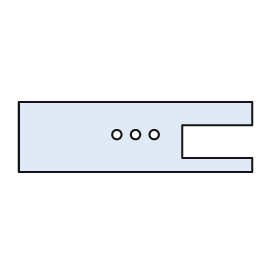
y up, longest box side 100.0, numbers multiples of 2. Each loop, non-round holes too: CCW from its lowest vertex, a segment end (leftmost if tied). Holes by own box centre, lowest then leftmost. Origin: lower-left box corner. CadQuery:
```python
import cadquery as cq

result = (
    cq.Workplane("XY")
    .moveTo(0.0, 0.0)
    .lineTo(100.0, 0.0)
    .lineTo(100.0, 6.0)
    .lineTo(70.0, 6.0)
    .lineTo(70.0, 20.0)
    .lineTo(100.0, 20.0)
    .lineTo(100.0, 30.0)
    .lineTo(0.0, 30.0)
    .close()
    .moveTo(42.0, 16.0)
    .circle(2.0)
    .moveTo(50.0, 16.0)
    .circle(2.0)
    .moveTo(58.0, 16.0)
    .circle(2.0)
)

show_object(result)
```